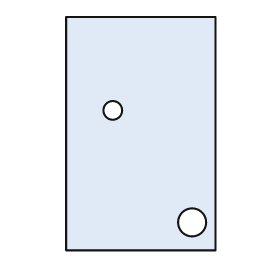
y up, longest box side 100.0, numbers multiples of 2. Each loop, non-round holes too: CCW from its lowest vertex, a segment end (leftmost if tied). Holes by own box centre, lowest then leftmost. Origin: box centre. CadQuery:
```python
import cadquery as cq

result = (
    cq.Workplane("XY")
    .moveTo(-32.0, -50.0)
    .lineTo(32.0, -50.0)
    .lineTo(32.0, 50.0)
    .lineTo(-32.0, 50.0)
    .close()
    .moveTo(22.0, -38.0)
    .circle(6.0)
    .moveTo(-12.0, 10.0)
    .circle(4.0)
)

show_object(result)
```